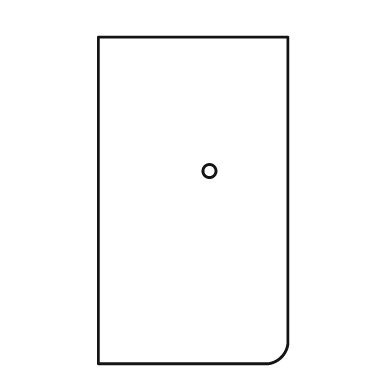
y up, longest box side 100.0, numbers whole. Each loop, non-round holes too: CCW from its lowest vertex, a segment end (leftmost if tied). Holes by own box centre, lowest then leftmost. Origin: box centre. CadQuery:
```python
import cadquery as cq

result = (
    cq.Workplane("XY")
    .moveTo(-29.0, -50.0)
    .lineTo(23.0, -50.0)
    .threePointArc((27.0, -48.0), (29.0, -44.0))
    .lineTo(29.0, 50.0)
    .lineTo(-29.0, 50.0)
    .close()
    .moveTo(5.0, 9.0)
    .circle(2.0)
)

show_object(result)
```